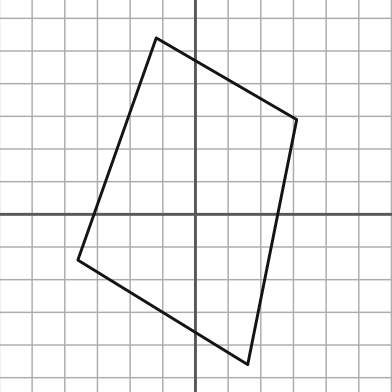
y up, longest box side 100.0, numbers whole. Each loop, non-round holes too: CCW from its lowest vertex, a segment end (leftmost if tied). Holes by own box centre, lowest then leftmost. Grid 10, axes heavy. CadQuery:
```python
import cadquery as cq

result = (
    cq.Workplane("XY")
    .moveTo(16.0, -46.0)
    .lineTo(31.0, 29.0)
    .lineTo(-12.0, 54.0)
    .lineTo(-36.0, -14.0)
    .close()
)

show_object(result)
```